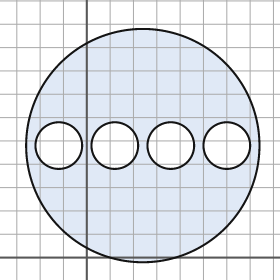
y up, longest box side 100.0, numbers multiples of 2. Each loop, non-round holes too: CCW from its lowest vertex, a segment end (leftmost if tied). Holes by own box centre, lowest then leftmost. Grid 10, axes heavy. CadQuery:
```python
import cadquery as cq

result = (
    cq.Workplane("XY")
    .moveTo(24.0, 48.0)
    .circle(50.0)
    .moveTo(-12.0, 48.0)
    .circle(10.0)
    .moveTo(12.0, 48.0)
    .circle(10.0)
    .moveTo(36.0, 48.0)
    .circle(10.0)
    .moveTo(60.0, 48.0)
    .circle(10.0)
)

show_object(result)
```